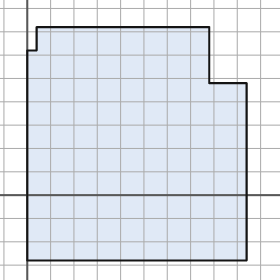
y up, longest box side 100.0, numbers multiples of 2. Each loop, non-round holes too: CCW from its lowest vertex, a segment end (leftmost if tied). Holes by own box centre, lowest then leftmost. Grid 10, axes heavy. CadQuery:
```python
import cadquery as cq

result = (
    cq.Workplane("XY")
    .moveTo(0.0, -28.0)
    .lineTo(94.0, -28.0)
    .lineTo(94.0, 48.0)
    .lineTo(78.0, 48.0)
    .lineTo(78.0, 72.0)
    .lineTo(4.0, 72.0)
    .lineTo(4.0, 62.0)
    .lineTo(0.0, 62.0)
    .close()
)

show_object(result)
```